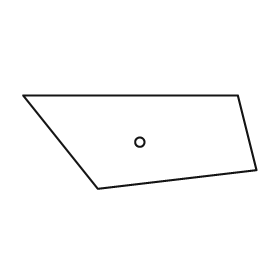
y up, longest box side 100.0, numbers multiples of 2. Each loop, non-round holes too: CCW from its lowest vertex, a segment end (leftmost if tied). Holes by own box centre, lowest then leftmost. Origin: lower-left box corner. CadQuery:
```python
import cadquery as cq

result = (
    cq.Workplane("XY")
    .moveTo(32.0, 0.0)
    .lineTo(100.0, 8.0)
    .lineTo(92.0, 40.0)
    .lineTo(0.0, 40.0)
    .close()
    .moveTo(50.0, 20.0)
    .circle(2.0)
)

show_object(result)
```